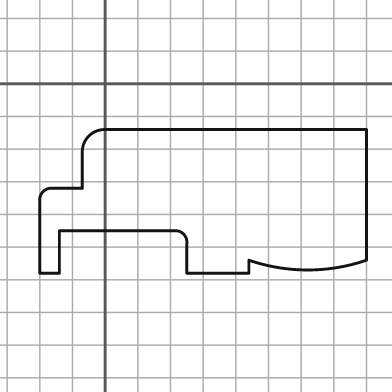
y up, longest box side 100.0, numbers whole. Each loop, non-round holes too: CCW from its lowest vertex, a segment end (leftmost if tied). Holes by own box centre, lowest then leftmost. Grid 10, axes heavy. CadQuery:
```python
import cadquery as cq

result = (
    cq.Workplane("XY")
    .moveTo(-20.0, -58.0)
    .lineTo(-14.0, -58.0)
    .lineTo(-14.0, -45.0)
    .lineTo(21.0, -45.0)
    .threePointArc((24.0, -46.0), (25.0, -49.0))
    .lineTo(25.0, -58.0)
    .lineTo(44.0, -58.0)
    .lineTo(44.0, -54.0)
    .threePointArc((62.0, -57.0), (80.0, -54.0))
    .lineTo(80.0, -14.0)
    .lineTo(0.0, -14.0)
    .threePointArc((-5.0, -16.0), (-7.0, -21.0))
    .lineTo(-7.0, -32.0)
    .lineTo(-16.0, -32.0)
    .threePointArc((-19.0, -33.0), (-20.0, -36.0))
    .close()
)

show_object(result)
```